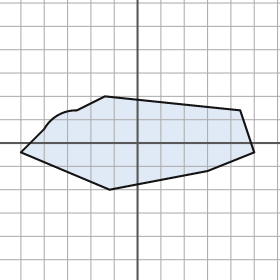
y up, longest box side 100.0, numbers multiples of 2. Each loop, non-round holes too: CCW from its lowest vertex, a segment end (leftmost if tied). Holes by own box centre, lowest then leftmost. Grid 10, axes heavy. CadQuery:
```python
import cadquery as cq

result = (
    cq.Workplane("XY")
    .moveTo(-12.0, -20.0)
    .lineTo(30.0, -12.0)
    .lineTo(50.0, -4.0)
    .lineTo(44.0, 14.0)
    .lineTo(-14.0, 20.0)
    .lineTo(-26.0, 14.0)
    .threePointArc((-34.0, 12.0), (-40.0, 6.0))
    .lineTo(-50.0, -4.0)
    .close()
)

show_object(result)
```